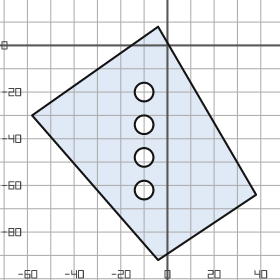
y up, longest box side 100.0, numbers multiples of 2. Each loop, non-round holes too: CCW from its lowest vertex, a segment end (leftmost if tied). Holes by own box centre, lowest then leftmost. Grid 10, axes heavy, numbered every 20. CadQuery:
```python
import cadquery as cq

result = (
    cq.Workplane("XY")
    .moveTo(-4.0, -92.0)
    .lineTo(38.0, -64.0)
    .lineTo(-4.0, 8.0)
    .lineTo(-58.0, -30.0)
    .close()
    .moveTo(-10.0, -62.0)
    .circle(4.0)
    .moveTo(-10.0, -48.0)
    .circle(4.0)
    .moveTo(-10.0, -34.0)
    .circle(4.0)
    .moveTo(-10.0, -20.0)
    .circle(4.0)
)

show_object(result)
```